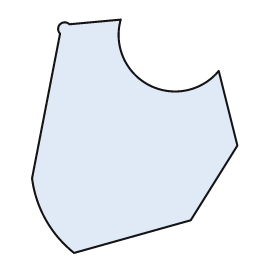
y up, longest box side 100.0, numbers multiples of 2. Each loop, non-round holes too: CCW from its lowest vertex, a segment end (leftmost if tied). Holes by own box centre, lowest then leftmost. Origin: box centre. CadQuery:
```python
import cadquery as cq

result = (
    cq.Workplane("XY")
    .moveTo(-26.0, -50.0)
    .lineTo(24.0, -36.0)
    .lineTo(44.0, -4.0)
    .lineTo(36.0, 28.0)
    .threePointArc((6.0, 22.0), (-6.0, 50.0))
    .lineTo(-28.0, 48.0)
    .threePointArc((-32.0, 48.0), (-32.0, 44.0))
    .lineTo(-44.0, -18.0)
    .threePointArc((-38.0, -36.0), (-26.0, -50.0))
    .close()
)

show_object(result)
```